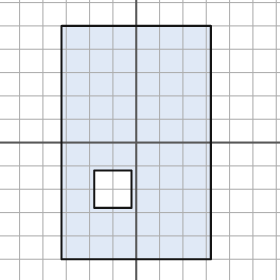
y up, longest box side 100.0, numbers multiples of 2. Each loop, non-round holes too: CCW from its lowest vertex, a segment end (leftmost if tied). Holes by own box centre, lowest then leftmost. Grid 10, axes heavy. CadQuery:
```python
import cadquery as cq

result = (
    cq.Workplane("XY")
    .moveTo(-32.0, -50.0)
    .lineTo(32.0, -50.0)
    .lineTo(32.0, 50.0)
    .lineTo(-32.0, 50.0)
    .close()
    .moveTo(-18.0, -28.0)
    .lineTo(-2.0, -28.0)
    .lineTo(-2.0, -12.0)
    .lineTo(-18.0, -12.0)
    .close()
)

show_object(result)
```